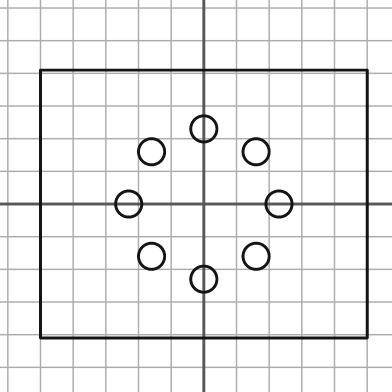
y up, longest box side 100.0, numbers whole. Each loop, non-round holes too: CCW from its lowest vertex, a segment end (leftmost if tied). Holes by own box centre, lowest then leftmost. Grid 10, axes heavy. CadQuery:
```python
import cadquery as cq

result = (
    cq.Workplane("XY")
    .moveTo(-50.0, -41.0)
    .lineTo(50.0, -41.0)
    .lineTo(50.0, 41.0)
    .lineTo(-50.0, 41.0)
    .close()
    .moveTo(0.0, -23.0)
    .circle(4.0)
    .moveTo(-16.0, -16.0)
    .circle(4.0)
    .moveTo(16.0, -16.0)
    .circle(4.0)
    .moveTo(-23.0, 0.0)
    .circle(4.0)
    .moveTo(23.0, 0.0)
    .circle(4.0)
    .moveTo(-16.0, 16.0)
    .circle(4.0)
    .moveTo(16.0, 16.0)
    .circle(4.0)
    .moveTo(0.0, 23.0)
    .circle(4.0)
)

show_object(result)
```